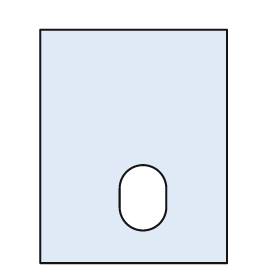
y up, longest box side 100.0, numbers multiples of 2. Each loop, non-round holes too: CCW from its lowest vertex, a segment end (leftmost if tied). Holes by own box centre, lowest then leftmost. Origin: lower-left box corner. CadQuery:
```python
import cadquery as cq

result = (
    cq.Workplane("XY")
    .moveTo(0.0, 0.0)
    .lineTo(80.0, 0.0)
    .lineTo(80.0, 100.0)
    .lineTo(0.0, 100.0)
    .close()
    .moveTo(34.0, 24.0)
    .threePointArc((44.0, 14.0), (54.0, 24.0))
    .lineTo(54.0, 32.0)
    .threePointArc((44.0, 42.0), (34.0, 32.0))
    .close()
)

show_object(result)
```